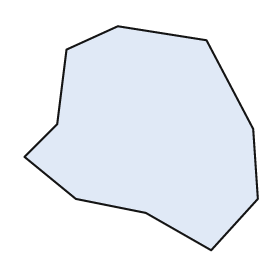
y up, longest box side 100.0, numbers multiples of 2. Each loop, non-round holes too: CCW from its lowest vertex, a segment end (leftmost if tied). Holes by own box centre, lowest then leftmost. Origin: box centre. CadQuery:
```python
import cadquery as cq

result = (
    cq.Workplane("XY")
    .moveTo(30.0, -48.0)
    .lineTo(50.0, -26.0)
    .lineTo(48.0, 4.0)
    .lineTo(28.0, 42.0)
    .lineTo(-10.0, 48.0)
    .lineTo(-32.0, 38.0)
    .lineTo(-36.0, 6.0)
    .lineTo(-50.0, -8.0)
    .lineTo(-28.0, -26.0)
    .lineTo(2.0, -32.0)
    .close()
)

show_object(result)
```